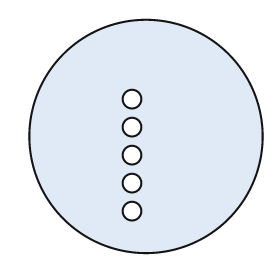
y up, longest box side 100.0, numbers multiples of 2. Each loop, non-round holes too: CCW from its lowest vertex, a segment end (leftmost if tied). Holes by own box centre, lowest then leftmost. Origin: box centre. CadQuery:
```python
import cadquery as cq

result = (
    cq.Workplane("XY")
    .moveTo(0.0, 0.0)
    .circle(50.0)
    .moveTo(-6.0, -32.0)
    .circle(4.0)
    .moveTo(-6.0, -20.0)
    .circle(4.0)
    .moveTo(-6.0, -8.0)
    .circle(4.0)
    .moveTo(-6.0, 4.0)
    .circle(4.0)
    .moveTo(-6.0, 16.0)
    .circle(4.0)
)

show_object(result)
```